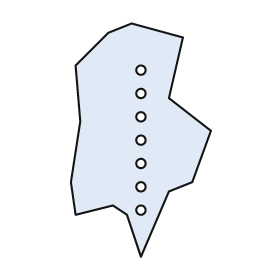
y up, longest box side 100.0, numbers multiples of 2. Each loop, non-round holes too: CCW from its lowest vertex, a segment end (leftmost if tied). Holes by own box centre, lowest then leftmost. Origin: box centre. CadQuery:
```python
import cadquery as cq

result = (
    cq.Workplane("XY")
    .moveTo(0.0, -50.0)
    .lineTo(12.0, -22.0)
    .lineTo(22.0, -18.0)
    .lineTo(30.0, 4.0)
    .lineTo(12.0, 18.0)
    .lineTo(18.0, 44.0)
    .lineTo(-4.0, 50.0)
    .lineTo(-14.0, 46.0)
    .lineTo(-28.0, 32.0)
    .lineTo(-26.0, 8.0)
    .lineTo(-30.0, -18.0)
    .lineTo(-28.0, -32.0)
    .lineTo(-12.0, -28.0)
    .lineTo(-6.0, -32.0)
    .close()
    .moveTo(0.0, -30.0)
    .circle(2.0)
    .moveTo(0.0, -20.0)
    .circle(2.0)
    .moveTo(0.0, -10.0)
    .circle(2.0)
    .moveTo(0.0, 0.0)
    .circle(2.0)
    .moveTo(0.0, 10.0)
    .circle(2.0)
    .moveTo(0.0, 20.0)
    .circle(2.0)
    .moveTo(0.0, 30.0)
    .circle(2.0)
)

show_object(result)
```